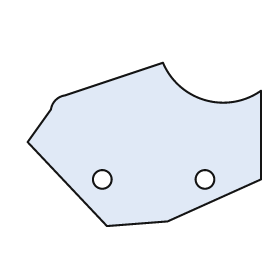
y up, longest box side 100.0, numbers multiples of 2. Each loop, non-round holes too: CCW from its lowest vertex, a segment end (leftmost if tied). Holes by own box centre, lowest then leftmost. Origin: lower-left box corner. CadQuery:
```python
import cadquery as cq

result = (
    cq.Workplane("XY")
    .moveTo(34.0, 0.0)
    .lineTo(60.0, 2.0)
    .lineTo(100.0, 20.0)
    .lineTo(100.0, 58.0)
    .threePointArc((76.0, 54.0), (58.0, 70.0))
    .lineTo(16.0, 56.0)
    .threePointArc((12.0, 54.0), (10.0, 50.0))
    .lineTo(0.0, 36.0)
    .close()
    .moveTo(32.0, 20.0)
    .circle(4.0)
    .moveTo(76.0, 20.0)
    .circle(4.0)
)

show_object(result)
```